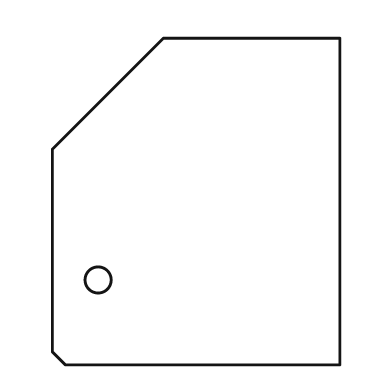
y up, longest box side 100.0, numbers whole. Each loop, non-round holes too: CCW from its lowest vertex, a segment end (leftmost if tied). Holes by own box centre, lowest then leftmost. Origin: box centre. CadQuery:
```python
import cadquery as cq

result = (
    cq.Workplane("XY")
    .moveTo(-40.0, -50.0)
    .lineTo(44.0, -50.0)
    .lineTo(44.0, 50.0)
    .lineTo(-10.0, 50.0)
    .lineTo(-44.0, 16.0)
    .lineTo(-44.0, -46.0)
    .close()
    .moveTo(-30.0, -24.0)
    .circle(4.0)
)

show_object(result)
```